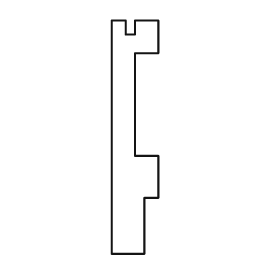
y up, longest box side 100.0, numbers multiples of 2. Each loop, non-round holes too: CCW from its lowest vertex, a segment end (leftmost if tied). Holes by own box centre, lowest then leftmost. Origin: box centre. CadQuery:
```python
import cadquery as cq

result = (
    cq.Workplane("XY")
    .moveTo(-10.0, -50.0)
    .lineTo(4.0, -50.0)
    .lineTo(4.0, -26.0)
    .lineTo(10.0, -26.0)
    .lineTo(10.0, -8.0)
    .lineTo(0.0, -8.0)
    .lineTo(0.0, 36.0)
    .lineTo(10.0, 36.0)
    .lineTo(10.0, 50.0)
    .lineTo(0.0, 50.0)
    .lineTo(0.0, 44.0)
    .lineTo(-4.0, 44.0)
    .lineTo(-4.0, 50.0)
    .lineTo(-10.0, 50.0)
    .close()
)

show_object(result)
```